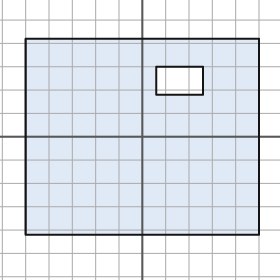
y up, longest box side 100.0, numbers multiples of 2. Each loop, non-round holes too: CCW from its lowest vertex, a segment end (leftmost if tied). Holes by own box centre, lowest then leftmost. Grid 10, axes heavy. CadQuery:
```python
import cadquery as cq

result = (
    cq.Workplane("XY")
    .moveTo(-50.0, -42.0)
    .lineTo(50.0, -42.0)
    .lineTo(50.0, 42.0)
    .lineTo(-50.0, 42.0)
    .close()
    .moveTo(6.0, 18.0)
    .lineTo(26.0, 18.0)
    .lineTo(26.0, 30.0)
    .lineTo(6.0, 30.0)
    .close()
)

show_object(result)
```